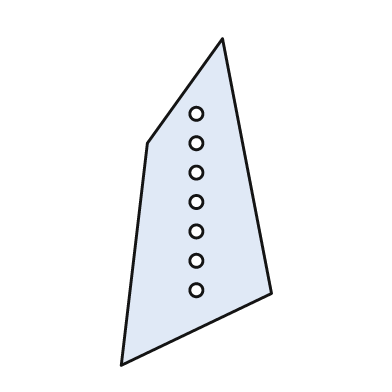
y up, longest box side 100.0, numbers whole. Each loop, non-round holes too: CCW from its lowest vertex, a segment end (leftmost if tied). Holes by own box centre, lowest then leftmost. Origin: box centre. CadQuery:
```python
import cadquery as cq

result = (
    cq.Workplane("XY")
    .moveTo(-23.0, -50.0)
    .lineTo(23.0, -28.0)
    .lineTo(8.0, 50.0)
    .lineTo(-15.0, 18.0)
    .close()
    .moveTo(0.0, -27.0)
    .circle(2.0)
    .moveTo(0.0, -18.0)
    .circle(2.0)
    .moveTo(0.0, -9.0)
    .circle(2.0)
    .moveTo(0.0, 0.0)
    .circle(2.0)
    .moveTo(0.0, 9.0)
    .circle(2.0)
    .moveTo(0.0, 18.0)
    .circle(2.0)
    .moveTo(0.0, 27.0)
    .circle(2.0)
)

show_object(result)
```